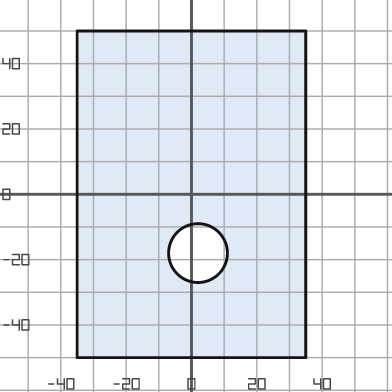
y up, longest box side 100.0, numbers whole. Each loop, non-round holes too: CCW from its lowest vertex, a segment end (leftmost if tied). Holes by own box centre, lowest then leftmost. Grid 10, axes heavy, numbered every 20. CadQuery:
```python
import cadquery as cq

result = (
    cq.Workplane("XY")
    .moveTo(-35.0, -50.0)
    .lineTo(35.0, -50.0)
    .lineTo(35.0, 50.0)
    .lineTo(-35.0, 50.0)
    .close()
    .moveTo(2.0, -18.0)
    .circle(9.0)
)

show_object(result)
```